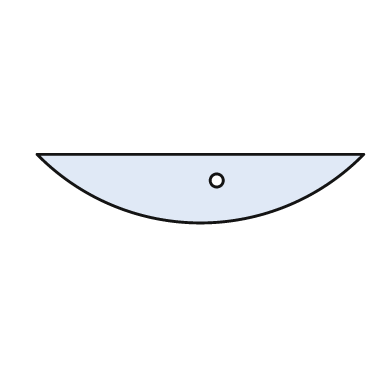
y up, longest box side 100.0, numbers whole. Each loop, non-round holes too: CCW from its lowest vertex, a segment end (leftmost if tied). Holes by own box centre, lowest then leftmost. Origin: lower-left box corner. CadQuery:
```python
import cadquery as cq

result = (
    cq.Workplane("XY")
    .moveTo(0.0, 21.0)
    .threePointArc((50.0, 0.0), (100.0, 21.0))
    .close()
    .moveTo(55.0, 13.0)
    .circle(2.0)
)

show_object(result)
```